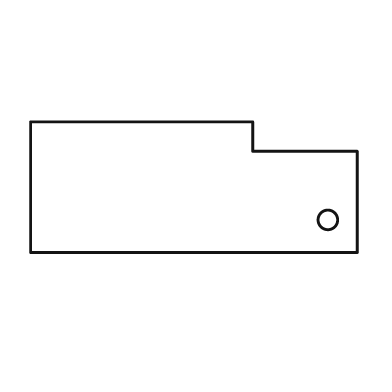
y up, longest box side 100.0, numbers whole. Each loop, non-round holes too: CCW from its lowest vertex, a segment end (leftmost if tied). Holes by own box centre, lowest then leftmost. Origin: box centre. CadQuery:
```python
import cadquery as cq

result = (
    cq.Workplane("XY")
    .moveTo(-50.0, -20.0)
    .lineTo(50.0, -20.0)
    .lineTo(50.0, 11.0)
    .lineTo(18.0, 11.0)
    .lineTo(18.0, 20.0)
    .lineTo(-50.0, 20.0)
    .close()
    .moveTo(41.0, -10.0)
    .circle(3.0)
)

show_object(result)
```